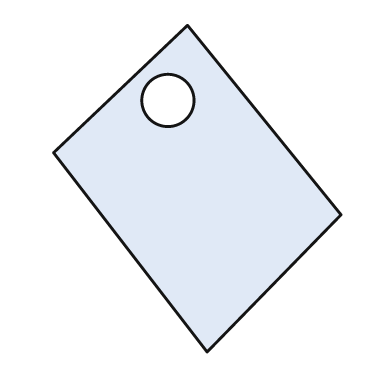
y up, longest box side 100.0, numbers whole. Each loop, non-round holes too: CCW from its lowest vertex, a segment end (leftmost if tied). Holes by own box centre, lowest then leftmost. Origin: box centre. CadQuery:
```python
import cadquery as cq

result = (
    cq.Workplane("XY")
    .moveTo(3.0, -50.0)
    .lineTo(44.0, -8.0)
    .lineTo(-3.0, 50.0)
    .lineTo(-44.0, 11.0)
    .close()
    .moveTo(-9.0, 27.0)
    .circle(8.0)
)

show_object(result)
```